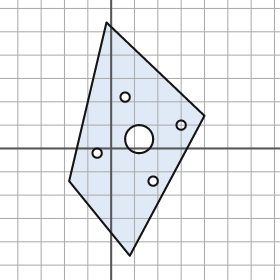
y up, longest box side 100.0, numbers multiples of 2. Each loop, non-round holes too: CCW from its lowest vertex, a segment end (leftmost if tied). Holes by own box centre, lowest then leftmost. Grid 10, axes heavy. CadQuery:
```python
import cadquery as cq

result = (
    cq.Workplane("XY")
    .moveTo(8.0, -46.0)
    .lineTo(40.0, 14.0)
    .lineTo(-2.0, 54.0)
    .lineTo(-18.0, -14.0)
    .close()
    .moveTo(18.0, -14.0)
    .circle(2.0)
    .moveTo(-6.0, -2.0)
    .circle(2.0)
    .moveTo(12.0, 4.0)
    .circle(6.0)
    .moveTo(30.0, 10.0)
    .circle(2.0)
    .moveTo(6.0, 22.0)
    .circle(2.0)
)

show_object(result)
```